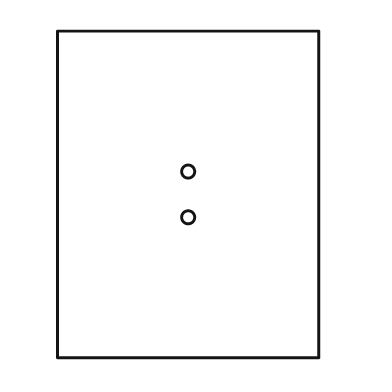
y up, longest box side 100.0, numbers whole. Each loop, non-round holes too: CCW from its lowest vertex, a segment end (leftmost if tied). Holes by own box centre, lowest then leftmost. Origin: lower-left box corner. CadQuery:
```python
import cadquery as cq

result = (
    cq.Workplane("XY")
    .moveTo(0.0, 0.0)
    .lineTo(80.0, 0.0)
    .lineTo(80.0, 100.0)
    .lineTo(0.0, 100.0)
    .close()
    .moveTo(40.0, 43.0)
    .circle(2.0)
    .moveTo(40.0, 57.0)
    .circle(2.0)
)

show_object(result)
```